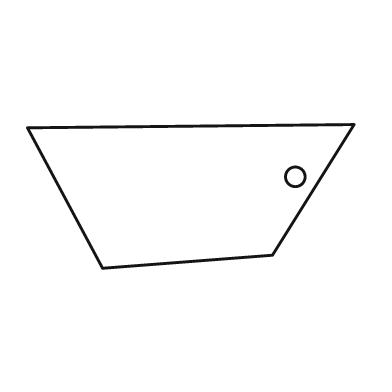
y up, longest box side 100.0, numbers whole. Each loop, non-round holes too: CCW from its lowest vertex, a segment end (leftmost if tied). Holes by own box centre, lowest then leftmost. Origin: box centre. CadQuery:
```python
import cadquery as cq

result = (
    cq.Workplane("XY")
    .moveTo(-27.0, -22.0)
    .lineTo(25.0, -18.0)
    .lineTo(50.0, 22.0)
    .lineTo(-50.0, 21.0)
    .close()
    .moveTo(32.0, 6.0)
    .circle(3.0)
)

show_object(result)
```